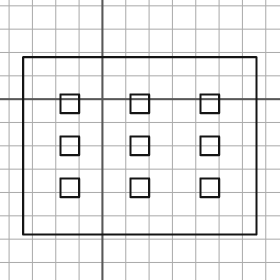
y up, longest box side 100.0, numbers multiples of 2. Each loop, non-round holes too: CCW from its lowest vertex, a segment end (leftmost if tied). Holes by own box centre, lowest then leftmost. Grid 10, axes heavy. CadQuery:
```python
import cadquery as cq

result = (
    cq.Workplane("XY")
    .moveTo(-34.0, -58.0)
    .lineTo(66.0, -58.0)
    .lineTo(66.0, 18.0)
    .lineTo(-34.0, 18.0)
    .close()
    .moveTo(-18.0, -42.0)
    .lineTo(-10.0, -42.0)
    .lineTo(-10.0, -34.0)
    .lineTo(-18.0, -34.0)
    .close()
    .moveTo(12.0, -42.0)
    .lineTo(20.0, -42.0)
    .lineTo(20.0, -34.0)
    .lineTo(12.0, -34.0)
    .close()
    .moveTo(42.0, -42.0)
    .lineTo(50.0, -42.0)
    .lineTo(50.0, -34.0)
    .lineTo(42.0, -34.0)
    .close()
    .moveTo(-18.0, -24.0)
    .lineTo(-10.0, -24.0)
    .lineTo(-10.0, -16.0)
    .lineTo(-18.0, -16.0)
    .close()
    .moveTo(12.0, -24.0)
    .lineTo(20.0, -24.0)
    .lineTo(20.0, -16.0)
    .lineTo(12.0, -16.0)
    .close()
    .moveTo(42.0, -24.0)
    .lineTo(50.0, -24.0)
    .lineTo(50.0, -16.0)
    .lineTo(42.0, -16.0)
    .close()
    .moveTo(-18.0, -6.0)
    .lineTo(-10.0, -6.0)
    .lineTo(-10.0, 2.0)
    .lineTo(-18.0, 2.0)
    .close()
    .moveTo(12.0, -6.0)
    .lineTo(20.0, -6.0)
    .lineTo(20.0, 2.0)
    .lineTo(12.0, 2.0)
    .close()
    .moveTo(42.0, -6.0)
    .lineTo(50.0, -6.0)
    .lineTo(50.0, 2.0)
    .lineTo(42.0, 2.0)
    .close()
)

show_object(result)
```